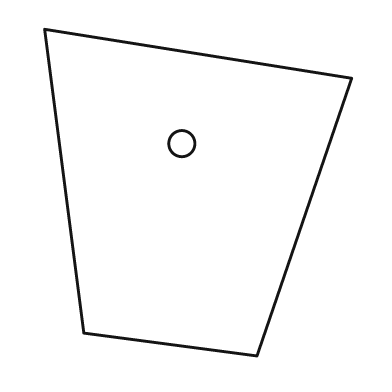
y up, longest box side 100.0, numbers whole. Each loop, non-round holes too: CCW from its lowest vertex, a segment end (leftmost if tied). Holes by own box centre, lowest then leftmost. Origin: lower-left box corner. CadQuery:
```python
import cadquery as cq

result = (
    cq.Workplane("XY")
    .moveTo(65.0, 0.0)
    .lineTo(94.0, 85.0)
    .lineTo(0.0, 100.0)
    .lineTo(12.0, 7.0)
    .close()
    .moveTo(42.0, 65.0)
    .circle(4.0)
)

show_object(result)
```